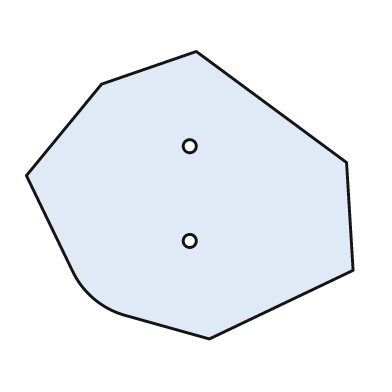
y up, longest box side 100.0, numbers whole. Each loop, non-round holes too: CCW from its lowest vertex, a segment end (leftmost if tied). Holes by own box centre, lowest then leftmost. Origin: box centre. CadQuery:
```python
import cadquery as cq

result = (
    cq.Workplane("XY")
    .moveTo(6.0, -44.0)
    .lineTo(50.0, -23.0)
    .lineTo(48.0, 10.0)
    .lineTo(2.0, 44.0)
    .lineTo(-27.0, 34.0)
    .lineTo(-50.0, 6.0)
    .lineTo(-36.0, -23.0)
    .threePointArc((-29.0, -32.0), (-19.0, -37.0))
    .close()
    .moveTo(0.0, -14.0)
    .circle(2.0)
    .moveTo(0.0, 15.0)
    .circle(2.0)
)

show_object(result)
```